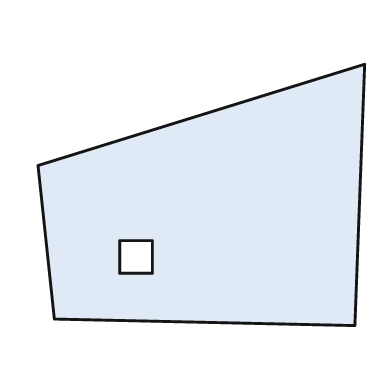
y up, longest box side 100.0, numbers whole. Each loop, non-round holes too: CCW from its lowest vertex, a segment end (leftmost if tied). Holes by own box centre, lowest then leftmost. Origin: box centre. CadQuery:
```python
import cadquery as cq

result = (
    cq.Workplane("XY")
    .moveTo(47.0, -40.0)
    .lineTo(50.0, 40.0)
    .lineTo(-50.0, 9.0)
    .lineTo(-45.0, -38.0)
    .close()
    .moveTo(-25.0, -24.0)
    .lineTo(-15.0, -24.0)
    .lineTo(-15.0, -14.0)
    .lineTo(-25.0, -14.0)
    .close()
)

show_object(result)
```